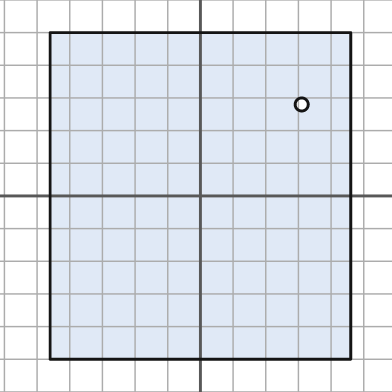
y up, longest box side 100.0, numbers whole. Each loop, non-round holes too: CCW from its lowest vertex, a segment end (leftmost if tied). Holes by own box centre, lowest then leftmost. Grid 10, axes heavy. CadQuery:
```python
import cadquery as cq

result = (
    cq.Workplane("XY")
    .moveTo(-46.0, -50.0)
    .lineTo(46.0, -50.0)
    .lineTo(46.0, 50.0)
    .lineTo(-46.0, 50.0)
    .close()
    .moveTo(31.0, 28.0)
    .circle(2.0)
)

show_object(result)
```